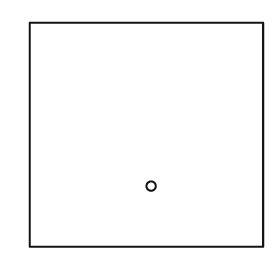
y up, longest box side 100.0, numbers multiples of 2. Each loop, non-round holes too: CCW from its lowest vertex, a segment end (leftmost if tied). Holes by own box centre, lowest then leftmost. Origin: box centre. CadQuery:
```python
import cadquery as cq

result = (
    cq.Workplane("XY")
    .moveTo(-50.0, -48.0)
    .lineTo(50.0, -48.0)
    .lineTo(50.0, 48.0)
    .lineTo(-50.0, 48.0)
    .close()
    .moveTo(2.0, -22.0)
    .circle(2.0)
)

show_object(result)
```